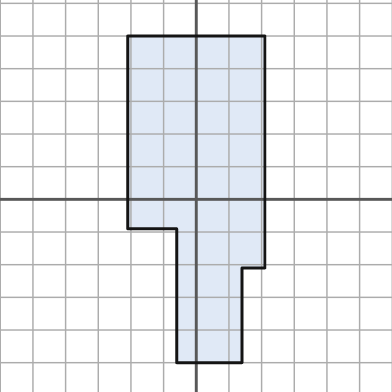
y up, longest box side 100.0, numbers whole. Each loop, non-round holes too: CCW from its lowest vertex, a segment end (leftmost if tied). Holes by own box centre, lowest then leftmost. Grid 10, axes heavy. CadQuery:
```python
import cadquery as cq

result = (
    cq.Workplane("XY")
    .moveTo(-6.0, -50.0)
    .lineTo(14.0, -50.0)
    .lineTo(14.0, -21.0)
    .lineTo(21.0, -21.0)
    .lineTo(21.0, 50.0)
    .lineTo(-21.0, 50.0)
    .lineTo(-21.0, -9.0)
    .lineTo(-6.0, -9.0)
    .close()
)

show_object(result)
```